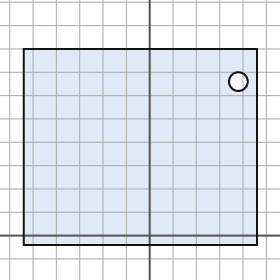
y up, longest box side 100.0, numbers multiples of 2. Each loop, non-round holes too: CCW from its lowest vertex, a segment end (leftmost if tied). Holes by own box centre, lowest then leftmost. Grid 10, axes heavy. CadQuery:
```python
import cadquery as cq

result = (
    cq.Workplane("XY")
    .moveTo(-54.0, -4.0)
    .lineTo(46.0, -4.0)
    .lineTo(46.0, 80.0)
    .lineTo(-54.0, 80.0)
    .close()
    .moveTo(38.0, 66.0)
    .circle(4.0)
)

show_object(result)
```